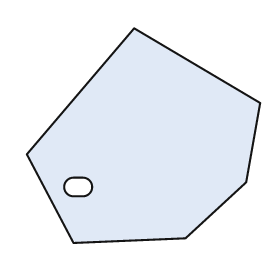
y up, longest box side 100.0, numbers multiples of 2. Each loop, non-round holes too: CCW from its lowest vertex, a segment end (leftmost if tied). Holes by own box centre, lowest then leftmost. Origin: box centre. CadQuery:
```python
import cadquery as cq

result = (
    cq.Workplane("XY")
    .moveTo(-30.0, -46.0)
    .lineTo(18.0, -44.0)
    .lineTo(44.0, -20.0)
    .lineTo(50.0, 14.0)
    .lineTo(-4.0, 46.0)
    .lineTo(-50.0, -8.0)
    .close()
    .moveTo(-30.0, -26.0)
    .lineTo(-26.0, -26.0)
    .threePointArc((-22.0, -22.0), (-26.0, -18.0))
    .lineTo(-30.0, -18.0)
    .threePointArc((-34.0, -22.0), (-30.0, -26.0))
    .close()
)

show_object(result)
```